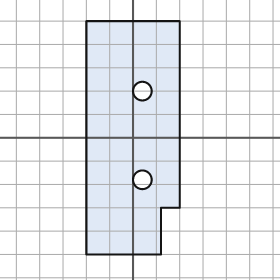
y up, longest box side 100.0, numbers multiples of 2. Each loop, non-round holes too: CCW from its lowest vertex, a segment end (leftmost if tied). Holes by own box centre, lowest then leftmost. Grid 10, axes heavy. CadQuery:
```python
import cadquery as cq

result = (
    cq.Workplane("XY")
    .moveTo(-20.0, -50.0)
    .lineTo(12.0, -50.0)
    .lineTo(12.0, -30.0)
    .lineTo(20.0, -30.0)
    .lineTo(20.0, 50.0)
    .lineTo(-20.0, 50.0)
    .close()
    .moveTo(4.0, -18.0)
    .circle(4.0)
    .moveTo(4.0, 20.0)
    .circle(4.0)
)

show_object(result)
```